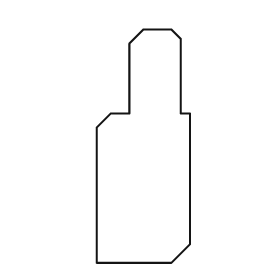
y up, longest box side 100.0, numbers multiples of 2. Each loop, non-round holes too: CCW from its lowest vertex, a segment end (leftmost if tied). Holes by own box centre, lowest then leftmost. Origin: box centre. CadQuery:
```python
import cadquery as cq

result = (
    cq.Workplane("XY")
    .moveTo(-20.0, -50.0)
    .lineTo(12.0, -50.0)
    .lineTo(20.0, -42.0)
    .lineTo(20.0, 14.0)
    .lineTo(16.0, 14.0)
    .lineTo(16.0, 46.0)
    .lineTo(12.0, 50.0)
    .lineTo(0.0, 50.0)
    .lineTo(-6.0, 44.0)
    .lineTo(-6.0, 14.0)
    .lineTo(-14.0, 14.0)
    .lineTo(-20.0, 8.0)
    .close()
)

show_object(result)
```